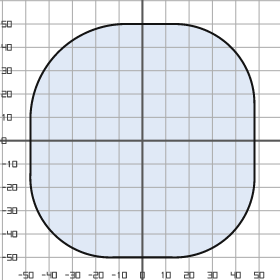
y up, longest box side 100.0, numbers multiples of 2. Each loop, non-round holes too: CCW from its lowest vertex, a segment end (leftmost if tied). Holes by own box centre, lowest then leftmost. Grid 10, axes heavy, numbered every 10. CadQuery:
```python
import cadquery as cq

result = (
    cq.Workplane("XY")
    .moveTo(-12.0, -50.0)
    .lineTo(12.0, -50.0)
    .threePointArc((38.0, -40.0), (48.0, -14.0))
    .lineTo(48.0, 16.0)
    .threePointArc((38.0, 40.0), (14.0, 50.0))
    .lineTo(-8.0, 50.0)
    .threePointArc((-36.0, 38.0), (-48.0, 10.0))
    .lineTo(-48.0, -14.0)
    .threePointArc((-38.0, -40.0), (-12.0, -50.0))
    .close()
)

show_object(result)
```